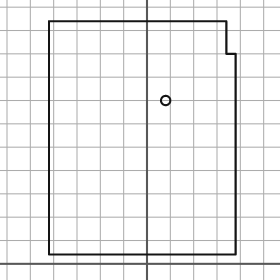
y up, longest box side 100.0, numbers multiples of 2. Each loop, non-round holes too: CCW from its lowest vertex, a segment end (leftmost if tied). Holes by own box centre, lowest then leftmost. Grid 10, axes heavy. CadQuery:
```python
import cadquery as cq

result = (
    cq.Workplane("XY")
    .moveTo(-42.0, 4.0)
    .lineTo(38.0, 4.0)
    .lineTo(38.0, 90.0)
    .lineTo(34.0, 90.0)
    .lineTo(34.0, 104.0)
    .lineTo(-42.0, 104.0)
    .close()
    .moveTo(8.0, 70.0)
    .circle(2.0)
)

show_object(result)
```